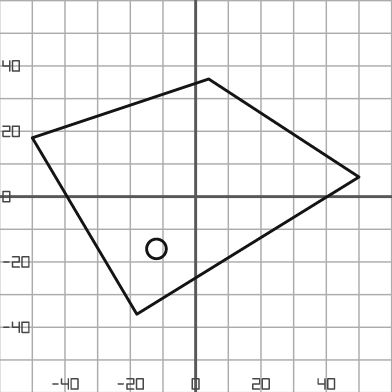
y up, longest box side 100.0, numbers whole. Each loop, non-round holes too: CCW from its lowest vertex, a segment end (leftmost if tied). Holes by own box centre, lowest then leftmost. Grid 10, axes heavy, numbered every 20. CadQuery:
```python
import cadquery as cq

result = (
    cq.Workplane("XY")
    .moveTo(-18.0, -36.0)
    .lineTo(50.0, 6.0)
    .lineTo(4.0, 36.0)
    .lineTo(-50.0, 18.0)
    .close()
    .moveTo(-12.0, -16.0)
    .circle(3.0)
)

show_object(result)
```